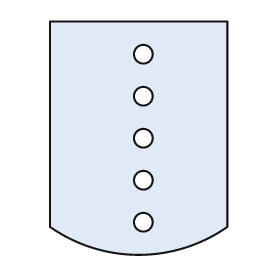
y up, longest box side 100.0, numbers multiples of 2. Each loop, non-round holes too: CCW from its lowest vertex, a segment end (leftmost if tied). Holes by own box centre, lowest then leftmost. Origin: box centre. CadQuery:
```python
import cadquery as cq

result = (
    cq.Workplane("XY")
    .moveTo(-38.0, -38.0)
    .threePointArc((0.0, -50.0), (38.0, -38.0))
    .lineTo(38.0, 50.0)
    .lineTo(-38.0, 50.0)
    .close()
    .moveTo(2.0, -36.0)
    .circle(4.0)
    .moveTo(2.0, -18.0)
    .circle(4.0)
    .moveTo(2.0, 0.0)
    .circle(4.0)
    .moveTo(2.0, 18.0)
    .circle(4.0)
    .moveTo(2.0, 36.0)
    .circle(4.0)
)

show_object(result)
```